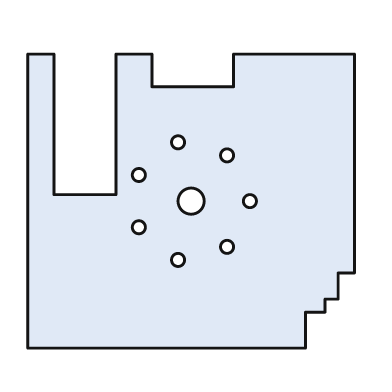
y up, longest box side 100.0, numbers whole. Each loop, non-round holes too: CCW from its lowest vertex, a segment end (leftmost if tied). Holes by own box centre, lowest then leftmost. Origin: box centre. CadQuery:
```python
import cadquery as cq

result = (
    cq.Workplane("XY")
    .moveTo(-50.0, -45.0)
    .lineTo(35.0, -45.0)
    .lineTo(35.0, -34.0)
    .lineTo(41.0, -34.0)
    .lineTo(41.0, -30.0)
    .lineTo(45.0, -30.0)
    .lineTo(45.0, -22.0)
    .lineTo(50.0, -22.0)
    .lineTo(50.0, 45.0)
    .lineTo(13.0, 45.0)
    .lineTo(13.0, 35.0)
    .lineTo(-12.0, 35.0)
    .lineTo(-12.0, 45.0)
    .lineTo(-23.0, 45.0)
    .lineTo(-23.0, 2.0)
    .lineTo(-42.0, 2.0)
    .lineTo(-42.0, 45.0)
    .lineTo(-50.0, 45.0)
    .close()
    .moveTo(-4.0, -18.0)
    .circle(2.0)
    .moveTo(11.0, -14.0)
    .circle(2.0)
    .moveTo(-16.0, -8.0)
    .circle(2.0)
    .moveTo(0.0, 0.0)
    .circle(4.0)
    .moveTo(18.0, 0.0)
    .circle(2.0)
    .moveTo(-16.0, 8.0)
    .circle(2.0)
    .moveTo(11.0, 14.0)
    .circle(2.0)
    .moveTo(-4.0, 18.0)
    .circle(2.0)
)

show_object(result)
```